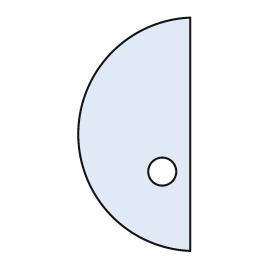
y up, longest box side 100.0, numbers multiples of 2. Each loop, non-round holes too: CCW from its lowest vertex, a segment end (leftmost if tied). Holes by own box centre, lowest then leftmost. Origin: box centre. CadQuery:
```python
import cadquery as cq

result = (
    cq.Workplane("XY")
    .moveTo(24.0, -50.0)
    .lineTo(24.0, 50.0)
    .threePointArc((-24.0, 0.0), (24.0, -50.0))
    .close()
    .moveTo(12.0, -16.0)
    .circle(6.0)
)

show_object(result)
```